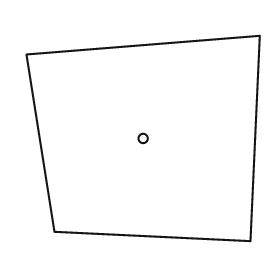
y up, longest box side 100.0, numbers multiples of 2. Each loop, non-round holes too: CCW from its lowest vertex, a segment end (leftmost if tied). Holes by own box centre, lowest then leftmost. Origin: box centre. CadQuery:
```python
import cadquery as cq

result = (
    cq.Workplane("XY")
    .moveTo(46.0, -44.0)
    .lineTo(50.0, 44.0)
    .lineTo(-50.0, 36.0)
    .lineTo(-38.0, -40.0)
    .close()
    .moveTo(0.0, 0.0)
    .circle(2.0)
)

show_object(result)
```